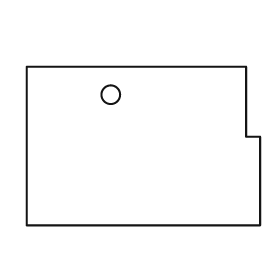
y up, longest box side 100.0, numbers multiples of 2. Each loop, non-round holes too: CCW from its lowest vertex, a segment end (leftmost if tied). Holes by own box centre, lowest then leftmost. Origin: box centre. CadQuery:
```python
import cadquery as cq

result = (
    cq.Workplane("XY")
    .moveTo(-50.0, -34.0)
    .lineTo(50.0, -34.0)
    .lineTo(50.0, 4.0)
    .lineTo(44.0, 4.0)
    .lineTo(44.0, 34.0)
    .lineTo(-50.0, 34.0)
    .close()
    .moveTo(-14.0, 22.0)
    .circle(4.0)
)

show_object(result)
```